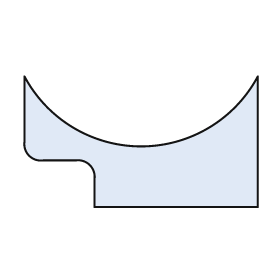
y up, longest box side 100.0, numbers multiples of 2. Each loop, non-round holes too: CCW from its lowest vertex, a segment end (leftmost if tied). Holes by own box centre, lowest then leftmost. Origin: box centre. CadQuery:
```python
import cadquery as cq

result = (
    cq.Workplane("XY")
    .moveTo(-20.0, -28.0)
    .lineTo(50.0, -28.0)
    .lineTo(50.0, 28.0)
    .threePointArc((0.0, -2.0), (-50.0, 28.0))
    .lineTo(-50.0, 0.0)
    .threePointArc((-48.0, -6.0), (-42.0, -8.0))
    .lineTo(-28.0, -8.0)
    .threePointArc((-22.0, -10.0), (-20.0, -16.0))
    .close()
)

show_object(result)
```